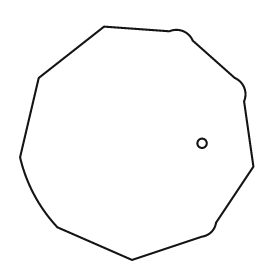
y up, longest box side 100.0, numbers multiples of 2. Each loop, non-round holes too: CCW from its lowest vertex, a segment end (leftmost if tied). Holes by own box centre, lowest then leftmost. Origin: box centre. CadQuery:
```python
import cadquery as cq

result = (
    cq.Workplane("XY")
    .moveTo(-2.0, -50.0)
    .lineTo(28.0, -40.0)
    .threePointArc((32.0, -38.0), (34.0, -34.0))
    .lineTo(50.0, -10.0)
    .lineTo(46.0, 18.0)
    .threePointArc((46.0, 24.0), (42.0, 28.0))
    .lineTo(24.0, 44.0)
    .threePointArc((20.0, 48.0), (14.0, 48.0))
    .lineTo(-14.0, 50.0)
    .lineTo(-42.0, 28.0)
    .lineTo(-50.0, -6.0)
    .threePointArc((-44.0, -22.0), (-34.0, -36.0))
    .close()
    .moveTo(28.0, 0.0)
    .circle(2.0)
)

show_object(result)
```